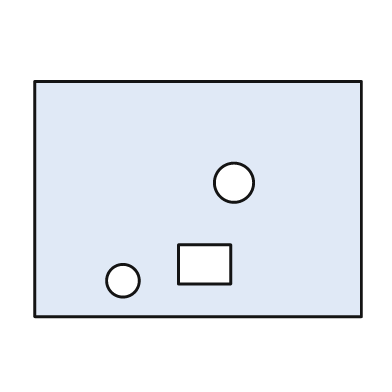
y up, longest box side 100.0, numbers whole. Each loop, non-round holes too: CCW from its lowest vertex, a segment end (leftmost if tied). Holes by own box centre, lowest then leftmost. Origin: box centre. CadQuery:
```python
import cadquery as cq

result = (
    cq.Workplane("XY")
    .moveTo(-50.0, -36.0)
    .lineTo(50.0, -36.0)
    .lineTo(50.0, 36.0)
    .lineTo(-50.0, 36.0)
    .close()
    .moveTo(-23.0, -25.0)
    .circle(5.0)
    .moveTo(-6.0, -26.0)
    .lineTo(10.0, -26.0)
    .lineTo(10.0, -14.0)
    .lineTo(-6.0, -14.0)
    .close()
    .moveTo(11.0, 5.0)
    .circle(6.0)
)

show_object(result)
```